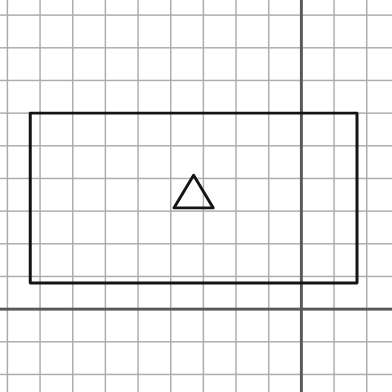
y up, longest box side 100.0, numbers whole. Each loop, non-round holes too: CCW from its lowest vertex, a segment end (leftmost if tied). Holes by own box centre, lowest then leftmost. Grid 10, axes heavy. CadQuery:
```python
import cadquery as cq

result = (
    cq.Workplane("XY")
    .moveTo(-83.0, 8.0)
    .lineTo(17.0, 8.0)
    .lineTo(17.0, 60.0)
    .lineTo(-83.0, 60.0)
    .close()
    .moveTo(-39.0, 31.0)
    .lineTo(-27.0, 31.0)
    .lineTo(-33.0, 41.0)
    .close()
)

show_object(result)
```